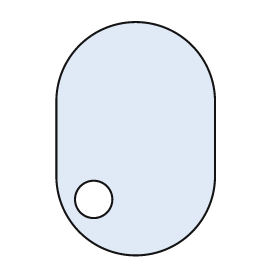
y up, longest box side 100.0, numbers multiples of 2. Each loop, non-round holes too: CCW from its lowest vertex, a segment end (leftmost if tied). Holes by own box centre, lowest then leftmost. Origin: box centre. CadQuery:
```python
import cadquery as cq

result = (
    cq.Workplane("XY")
    .moveTo(-34.0, -16.0)
    .threePointArc((0.0, -50.0), (34.0, -16.0))
    .lineTo(34.0, 16.0)
    .threePointArc((0.0, 50.0), (-34.0, 16.0))
    .close()
    .moveTo(-18.0, -26.0)
    .circle(8.0)
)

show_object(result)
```